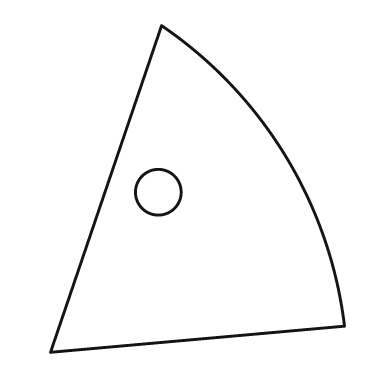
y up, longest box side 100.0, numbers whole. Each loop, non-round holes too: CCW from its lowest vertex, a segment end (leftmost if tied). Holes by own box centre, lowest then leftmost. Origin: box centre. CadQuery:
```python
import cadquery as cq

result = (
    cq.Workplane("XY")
    .moveTo(-45.0, -50.0)
    .lineTo(45.0, -42.0)
    .threePointArc((27.0, 10.0), (-11.0, 50.0))
    .close()
    .moveTo(-12.0, -1.0)
    .circle(7.0)
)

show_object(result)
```